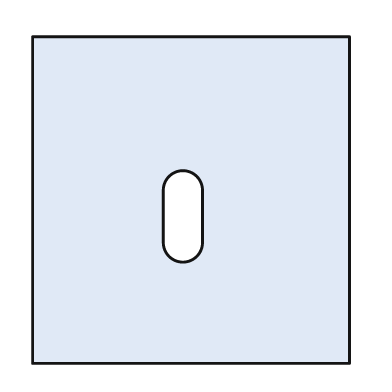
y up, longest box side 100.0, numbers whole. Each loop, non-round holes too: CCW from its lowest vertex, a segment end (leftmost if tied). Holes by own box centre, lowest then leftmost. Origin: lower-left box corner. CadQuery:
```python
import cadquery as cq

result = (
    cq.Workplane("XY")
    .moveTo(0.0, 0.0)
    .lineTo(97.0, 0.0)
    .lineTo(97.0, 100.0)
    .lineTo(0.0, 100.0)
    .close()
    .moveTo(40.0, 37.0)
    .threePointArc((46.0, 31.0), (52.0, 37.0))
    .lineTo(52.0, 53.0)
    .threePointArc((46.0, 59.0), (40.0, 53.0))
    .close()
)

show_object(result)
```